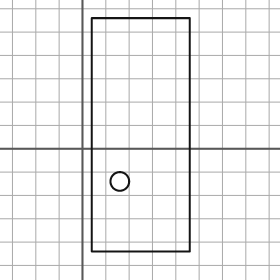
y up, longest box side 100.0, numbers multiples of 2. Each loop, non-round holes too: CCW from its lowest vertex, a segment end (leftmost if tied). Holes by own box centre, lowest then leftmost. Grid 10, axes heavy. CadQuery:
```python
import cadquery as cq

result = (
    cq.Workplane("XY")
    .moveTo(4.0, -44.0)
    .lineTo(46.0, -44.0)
    .lineTo(46.0, 56.0)
    .lineTo(4.0, 56.0)
    .close()
    .moveTo(16.0, -14.0)
    .circle(4.0)
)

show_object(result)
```